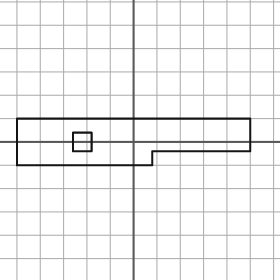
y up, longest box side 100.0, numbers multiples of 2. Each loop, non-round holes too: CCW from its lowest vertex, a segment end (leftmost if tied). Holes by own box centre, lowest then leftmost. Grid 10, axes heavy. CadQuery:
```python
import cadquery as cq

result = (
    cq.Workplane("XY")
    .moveTo(-50.0, -10.0)
    .lineTo(8.0, -10.0)
    .lineTo(8.0, -4.0)
    .lineTo(50.0, -4.0)
    .lineTo(50.0, 10.0)
    .lineTo(-50.0, 10.0)
    .close()
    .moveTo(-26.0, -4.0)
    .lineTo(-18.0, -4.0)
    .lineTo(-18.0, 4.0)
    .lineTo(-26.0, 4.0)
    .close()
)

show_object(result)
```